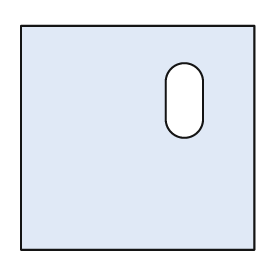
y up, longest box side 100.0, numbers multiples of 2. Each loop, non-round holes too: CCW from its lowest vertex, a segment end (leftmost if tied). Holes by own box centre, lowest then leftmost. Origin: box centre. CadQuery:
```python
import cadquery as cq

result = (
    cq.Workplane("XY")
    .moveTo(-50.0, -48.0)
    .lineTo(50.0, -48.0)
    .lineTo(50.0, 48.0)
    .lineTo(-50.0, 48.0)
    .close()
    .moveTo(12.0, 8.0)
    .threePointArc((20.0, 0.0), (28.0, 8.0))
    .lineTo(28.0, 24.0)
    .threePointArc((20.0, 32.0), (12.0, 24.0))
    .close()
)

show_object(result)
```